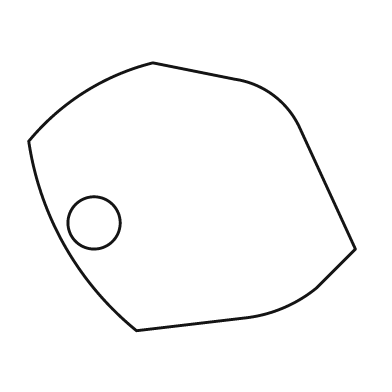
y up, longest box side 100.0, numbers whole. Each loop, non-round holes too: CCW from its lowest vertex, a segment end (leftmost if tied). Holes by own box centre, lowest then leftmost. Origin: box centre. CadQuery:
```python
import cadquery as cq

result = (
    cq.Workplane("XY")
    .moveTo(-17.0, -41.0)
    .lineTo(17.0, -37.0)
    .threePointArc((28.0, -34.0), (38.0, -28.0))
    .lineTo(50.0, -16.0)
    .lineTo(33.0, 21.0)
    .threePointArc((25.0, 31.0), (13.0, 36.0))
    .lineTo(-12.0, 41.0)
    .threePointArc((-33.0, 32.0), (-50.0, 17.0))
    .threePointArc((-39.0, -15.0), (-17.0, -41.0))
    .close()
    .moveTo(-30.0, -8.0)
    .circle(8.0)
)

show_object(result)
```